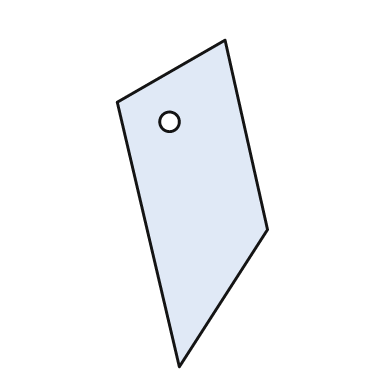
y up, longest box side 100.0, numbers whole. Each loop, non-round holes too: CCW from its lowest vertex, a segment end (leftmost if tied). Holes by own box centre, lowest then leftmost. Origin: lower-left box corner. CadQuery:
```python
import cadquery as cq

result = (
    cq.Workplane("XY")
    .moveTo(19.0, 0.0)
    .lineTo(46.0, 42.0)
    .lineTo(33.0, 100.0)
    .lineTo(0.0, 81.0)
    .close()
    .moveTo(16.0, 75.0)
    .circle(3.0)
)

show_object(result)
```